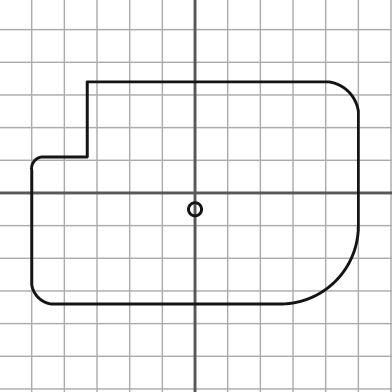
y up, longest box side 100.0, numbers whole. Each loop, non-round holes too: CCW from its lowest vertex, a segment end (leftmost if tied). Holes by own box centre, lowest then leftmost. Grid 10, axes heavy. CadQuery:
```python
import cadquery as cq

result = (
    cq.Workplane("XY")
    .moveTo(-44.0, -34.0)
    .lineTo(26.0, -34.0)
    .threePointArc((43.0, -27.0), (50.0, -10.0))
    .lineTo(50.0, 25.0)
    .threePointArc((47.0, 31.0), (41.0, 34.0))
    .lineTo(-33.0, 34.0)
    .lineTo(-33.0, 11.0)
    .lineTo(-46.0, 11.0)
    .threePointArc((-49.0, 10.0), (-50.0, 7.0))
    .lineTo(-50.0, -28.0)
    .threePointArc((-48.0, -32.0), (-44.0, -34.0))
    .close()
    .moveTo(0.0, -5.0)
    .circle(2.0)
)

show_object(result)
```